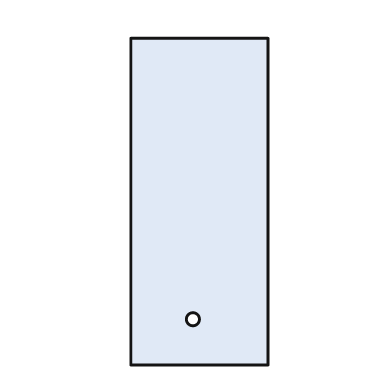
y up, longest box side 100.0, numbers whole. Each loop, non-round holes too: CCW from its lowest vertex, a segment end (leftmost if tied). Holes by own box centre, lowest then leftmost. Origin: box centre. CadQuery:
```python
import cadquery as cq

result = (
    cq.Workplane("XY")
    .moveTo(-21.0, -50.0)
    .lineTo(21.0, -50.0)
    .lineTo(21.0, 50.0)
    .lineTo(-21.0, 50.0)
    .close()
    .moveTo(-2.0, -36.0)
    .circle(2.0)
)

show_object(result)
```